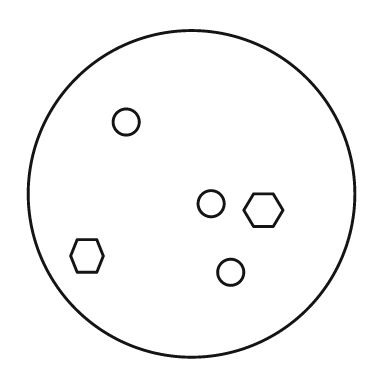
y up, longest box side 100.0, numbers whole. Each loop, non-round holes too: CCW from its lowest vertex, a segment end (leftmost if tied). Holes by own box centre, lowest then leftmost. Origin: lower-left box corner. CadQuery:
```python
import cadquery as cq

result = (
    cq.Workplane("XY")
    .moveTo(50.0, 50.0)
    .circle(50.0)
    .moveTo(62.0, 26.0)
    .circle(4.0)
    .moveTo(15.0, 26.0)
    .lineTo(21.0, 26.0)
    .lineTo(23.0, 31.0)
    .lineTo(21.0, 36.0)
    .lineTo(15.0, 36.0)
    .lineTo(13.0, 31.0)
    .close()
    .moveTo(69.0, 40.0)
    .lineTo(75.0, 40.0)
    .lineTo(78.0, 45.0)
    .lineTo(75.0, 50.0)
    .lineTo(69.0, 50.0)
    .lineTo(66.0, 45.0)
    .close()
    .moveTo(56.0, 47.0)
    .circle(4.0)
    .moveTo(30.0, 72.0)
    .circle(4.0)
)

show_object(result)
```